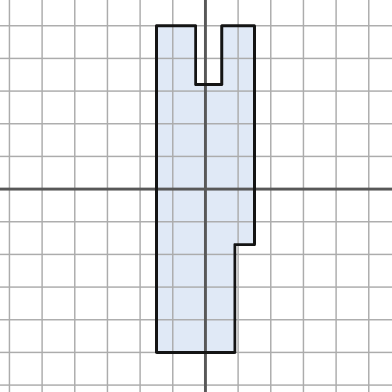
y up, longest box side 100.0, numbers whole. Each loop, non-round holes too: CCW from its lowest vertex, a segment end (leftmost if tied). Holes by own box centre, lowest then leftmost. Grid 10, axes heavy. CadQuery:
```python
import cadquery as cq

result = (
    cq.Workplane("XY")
    .moveTo(-15.0, -50.0)
    .lineTo(9.0, -50.0)
    .lineTo(9.0, -17.0)
    .lineTo(15.0, -17.0)
    .lineTo(15.0, 50.0)
    .lineTo(5.0, 50.0)
    .lineTo(5.0, 32.0)
    .lineTo(-3.0, 32.0)
    .lineTo(-3.0, 50.0)
    .lineTo(-15.0, 50.0)
    .close()
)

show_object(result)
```